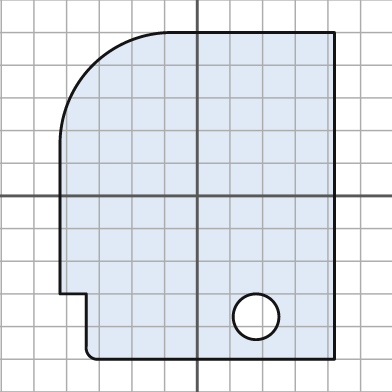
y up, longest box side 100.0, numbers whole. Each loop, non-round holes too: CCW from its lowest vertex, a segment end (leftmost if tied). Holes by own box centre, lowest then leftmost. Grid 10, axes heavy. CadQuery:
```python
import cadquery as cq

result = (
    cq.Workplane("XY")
    .moveTo(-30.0, -50.0)
    .lineTo(42.0, -50.0)
    .lineTo(42.0, 50.0)
    .lineTo(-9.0, 50.0)
    .threePointArc((-32.0, 40.0), (-42.0, 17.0))
    .lineTo(-42.0, -30.0)
    .lineTo(-34.0, -30.0)
    .lineTo(-34.0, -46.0)
    .threePointArc((-33.0, -49.0), (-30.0, -50.0))
    .close()
    .moveTo(18.0, -37.0)
    .circle(7.0)
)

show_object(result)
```